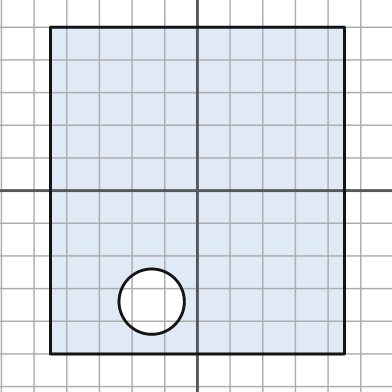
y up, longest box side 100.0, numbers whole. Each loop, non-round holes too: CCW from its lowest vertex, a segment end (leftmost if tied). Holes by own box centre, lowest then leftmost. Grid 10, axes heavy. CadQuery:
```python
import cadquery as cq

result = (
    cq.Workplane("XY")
    .moveTo(-45.0, -50.0)
    .lineTo(45.0, -50.0)
    .lineTo(45.0, 50.0)
    .lineTo(-45.0, 50.0)
    .close()
    .moveTo(-14.0, -34.0)
    .circle(10.0)
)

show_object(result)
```